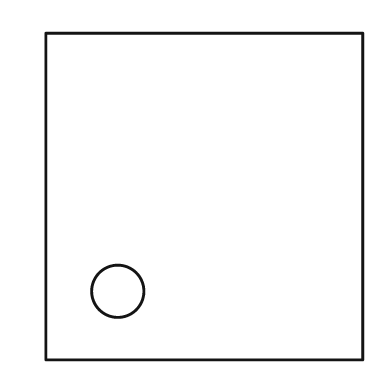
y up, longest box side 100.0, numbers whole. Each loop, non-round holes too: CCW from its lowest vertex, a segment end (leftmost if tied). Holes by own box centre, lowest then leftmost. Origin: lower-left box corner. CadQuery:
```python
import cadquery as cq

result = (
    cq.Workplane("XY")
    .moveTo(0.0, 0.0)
    .lineTo(97.0, 0.0)
    .lineTo(97.0, 100.0)
    .lineTo(0.0, 100.0)
    .close()
    .moveTo(22.0, 21.0)
    .circle(8.0)
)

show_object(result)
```